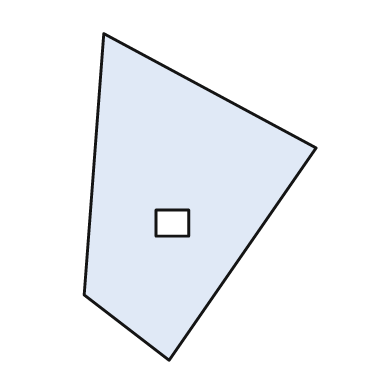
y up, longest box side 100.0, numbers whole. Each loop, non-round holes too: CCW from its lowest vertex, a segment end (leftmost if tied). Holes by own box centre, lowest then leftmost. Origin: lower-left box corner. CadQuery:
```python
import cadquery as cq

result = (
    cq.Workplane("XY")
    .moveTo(26.0, 0.0)
    .lineTo(71.0, 65.0)
    .lineTo(6.0, 100.0)
    .lineTo(0.0, 20.0)
    .close()
    .moveTo(22.0, 38.0)
    .lineTo(32.0, 38.0)
    .lineTo(32.0, 46.0)
    .lineTo(22.0, 46.0)
    .close()
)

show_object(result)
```